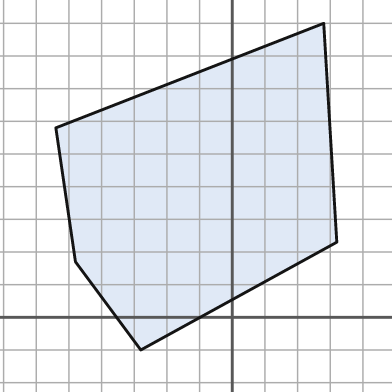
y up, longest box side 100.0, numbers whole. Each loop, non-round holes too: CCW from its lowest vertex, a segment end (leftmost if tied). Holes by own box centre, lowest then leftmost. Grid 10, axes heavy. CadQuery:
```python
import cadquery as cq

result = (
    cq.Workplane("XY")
    .moveTo(-28.0, -10.0)
    .lineTo(32.0, 23.0)
    .lineTo(28.0, 90.0)
    .lineTo(-54.0, 58.0)
    .lineTo(-48.0, 17.0)
    .close()
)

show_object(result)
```